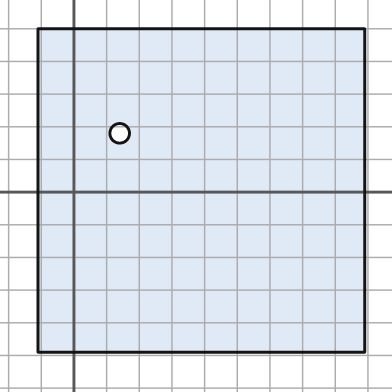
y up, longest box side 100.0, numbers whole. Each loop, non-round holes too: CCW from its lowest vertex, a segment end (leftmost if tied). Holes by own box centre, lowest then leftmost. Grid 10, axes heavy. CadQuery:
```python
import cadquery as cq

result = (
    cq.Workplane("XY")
    .moveTo(-11.0, -49.0)
    .lineTo(89.0, -49.0)
    .lineTo(89.0, 50.0)
    .lineTo(-11.0, 50.0)
    .close()
    .moveTo(14.0, 18.0)
    .circle(3.0)
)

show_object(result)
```